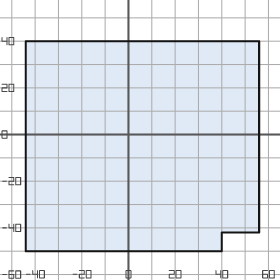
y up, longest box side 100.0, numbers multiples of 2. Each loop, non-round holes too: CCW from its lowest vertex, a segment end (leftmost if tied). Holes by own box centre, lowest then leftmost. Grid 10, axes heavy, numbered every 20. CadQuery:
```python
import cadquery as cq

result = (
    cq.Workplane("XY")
    .moveTo(-44.0, -50.0)
    .lineTo(40.0, -50.0)
    .lineTo(40.0, -42.0)
    .lineTo(56.0, -42.0)
    .lineTo(56.0, 40.0)
    .lineTo(-44.0, 40.0)
    .close()
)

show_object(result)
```